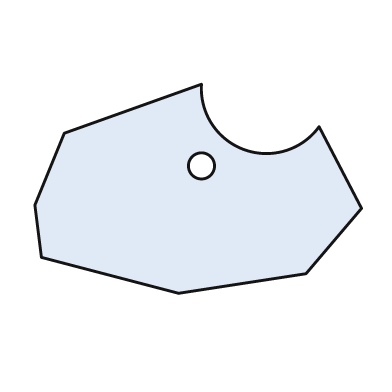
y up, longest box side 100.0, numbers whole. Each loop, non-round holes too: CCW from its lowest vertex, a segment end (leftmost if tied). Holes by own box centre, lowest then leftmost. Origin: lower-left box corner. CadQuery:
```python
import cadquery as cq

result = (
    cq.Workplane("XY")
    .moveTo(44.0, 0.0)
    .lineTo(83.0, 6.0)
    .lineTo(100.0, 26.0)
    .lineTo(87.0, 51.0)
    .threePointArc((64.0, 44.0), (51.0, 64.0))
    .lineTo(9.0, 49.0)
    .lineTo(0.0, 27.0)
    .lineTo(2.0, 11.0)
    .close()
    .moveTo(51.0, 39.0)
    .circle(4.0)
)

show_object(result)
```